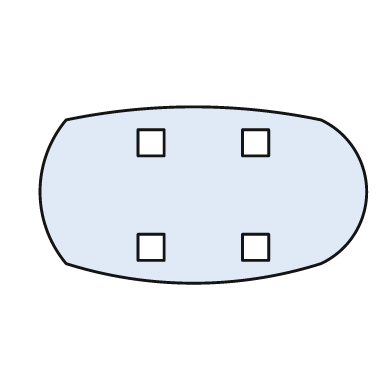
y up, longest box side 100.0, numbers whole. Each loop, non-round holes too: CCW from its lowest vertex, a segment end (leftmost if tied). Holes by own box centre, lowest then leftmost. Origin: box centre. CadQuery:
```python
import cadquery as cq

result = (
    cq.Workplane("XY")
    .moveTo(-42.0, -21.0)
    .threePointArc((-3.0, -27.0), (36.0, -21.0))
    .threePointArc((50.0, 1.0), (36.0, 23.0))
    .threePointArc((-3.0, 27.0), (-42.0, 23.0))
    .threePointArc((-50.0, 1.0), (-42.0, -21.0))
    .close()
    .moveTo(-20.0, -20.0)
    .lineTo(-12.0, -20.0)
    .lineTo(-12.0, -12.0)
    .lineTo(-20.0, -12.0)
    .close()
    .moveTo(12.0, -20.0)
    .lineTo(20.0, -20.0)
    .lineTo(20.0, -12.0)
    .lineTo(12.0, -12.0)
    .close()
    .moveTo(-20.0, 12.0)
    .lineTo(-12.0, 12.0)
    .lineTo(-12.0, 20.0)
    .lineTo(-20.0, 20.0)
    .close()
    .moveTo(12.0, 12.0)
    .lineTo(20.0, 12.0)
    .lineTo(20.0, 20.0)
    .lineTo(12.0, 20.0)
    .close()
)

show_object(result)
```